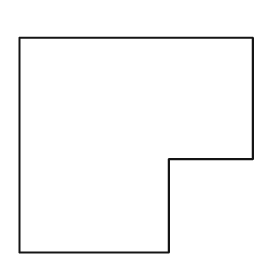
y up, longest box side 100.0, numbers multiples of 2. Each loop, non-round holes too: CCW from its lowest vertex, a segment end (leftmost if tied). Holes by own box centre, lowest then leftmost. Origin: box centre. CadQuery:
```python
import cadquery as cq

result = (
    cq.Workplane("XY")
    .moveTo(-50.0, -46.0)
    .lineTo(14.0, -46.0)
    .lineTo(14.0, -6.0)
    .lineTo(50.0, -6.0)
    .lineTo(50.0, 46.0)
    .lineTo(-50.0, 46.0)
    .close()
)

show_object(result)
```